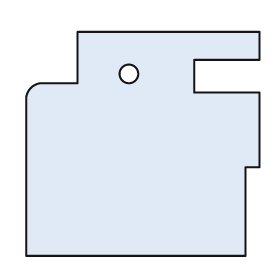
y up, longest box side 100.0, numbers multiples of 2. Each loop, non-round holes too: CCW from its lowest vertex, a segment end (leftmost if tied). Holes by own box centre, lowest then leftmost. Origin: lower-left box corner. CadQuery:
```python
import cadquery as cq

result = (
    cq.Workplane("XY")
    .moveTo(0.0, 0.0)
    .lineTo(94.0, 0.0)
    .lineTo(94.0, 38.0)
    .lineTo(100.0, 38.0)
    .lineTo(100.0, 70.0)
    .lineTo(72.0, 70.0)
    .lineTo(72.0, 84.0)
    .lineTo(100.0, 84.0)
    .lineTo(100.0, 96.0)
    .lineTo(22.0, 96.0)
    .lineTo(22.0, 74.0)
    .lineTo(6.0, 74.0)
    .threePointArc((2.0, 72.0), (0.0, 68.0))
    .close()
    .moveTo(44.0, 78.0)
    .circle(4.0)
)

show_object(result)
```